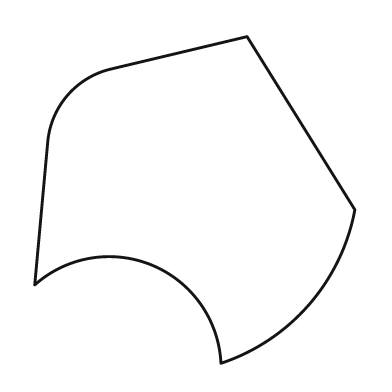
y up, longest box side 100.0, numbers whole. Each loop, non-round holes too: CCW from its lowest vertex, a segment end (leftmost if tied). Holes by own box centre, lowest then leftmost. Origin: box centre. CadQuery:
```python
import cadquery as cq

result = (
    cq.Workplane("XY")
    .moveTo(8.0, -50.0)
    .threePointArc((35.0, -32.0), (49.0, -3.0))
    .lineTo(16.0, 50.0)
    .lineTo(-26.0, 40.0)
    .threePointArc((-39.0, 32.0), (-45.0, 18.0))
    .lineTo(-49.0, -26.0)
    .threePointArc((-13.0, -20.0), (8.0, -50.0))
    .close()
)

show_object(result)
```